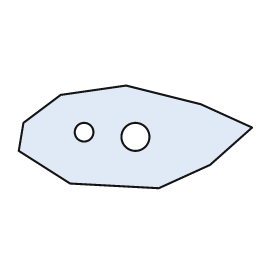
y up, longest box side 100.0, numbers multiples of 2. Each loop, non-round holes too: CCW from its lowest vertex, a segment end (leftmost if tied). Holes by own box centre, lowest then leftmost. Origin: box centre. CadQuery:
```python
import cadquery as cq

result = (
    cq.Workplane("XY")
    .moveTo(10.0, -22.0)
    .lineTo(32.0, -12.0)
    .lineTo(50.0, 4.0)
    .lineTo(28.0, 14.0)
    .lineTo(-4.0, 22.0)
    .lineTo(-32.0, 18.0)
    .lineTo(-48.0, 6.0)
    .lineTo(-50.0, -6.0)
    .lineTo(-28.0, -20.0)
    .close()
    .moveTo(0.0, 0.0)
    .circle(6.0)
    .moveTo(-22.0, 2.0)
    .circle(4.0)
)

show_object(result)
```